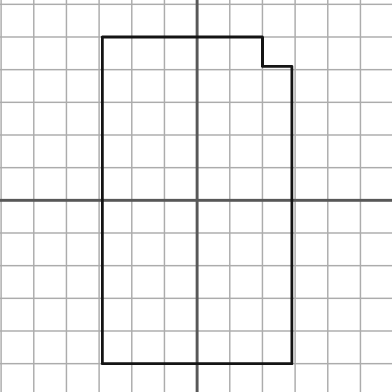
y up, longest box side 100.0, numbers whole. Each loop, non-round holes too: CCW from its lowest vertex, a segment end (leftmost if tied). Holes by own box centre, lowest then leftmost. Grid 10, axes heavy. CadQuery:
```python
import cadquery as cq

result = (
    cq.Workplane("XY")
    .moveTo(-29.0, -50.0)
    .lineTo(29.0, -50.0)
    .lineTo(29.0, 41.0)
    .lineTo(20.0, 41.0)
    .lineTo(20.0, 50.0)
    .lineTo(-29.0, 50.0)
    .close()
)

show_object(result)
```